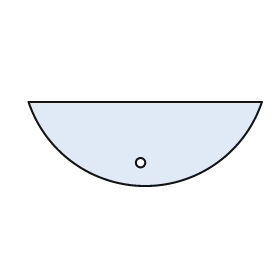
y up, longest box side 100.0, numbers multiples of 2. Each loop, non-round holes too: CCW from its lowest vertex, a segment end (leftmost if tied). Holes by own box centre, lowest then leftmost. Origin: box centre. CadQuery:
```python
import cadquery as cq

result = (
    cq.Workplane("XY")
    .moveTo(-50.0, 18.0)
    .threePointArc((0.0, -18.0), (50.0, 18.0))
    .close()
    .moveTo(-2.0, -8.0)
    .circle(2.0)
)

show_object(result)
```